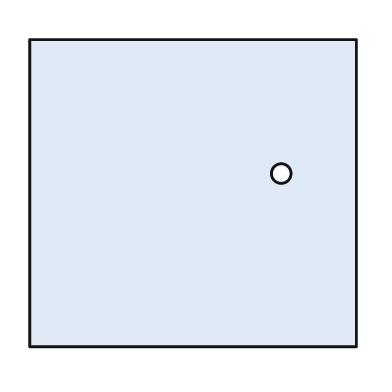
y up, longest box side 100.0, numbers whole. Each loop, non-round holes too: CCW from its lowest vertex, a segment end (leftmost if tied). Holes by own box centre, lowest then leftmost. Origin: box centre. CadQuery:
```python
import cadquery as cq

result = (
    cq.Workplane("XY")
    .moveTo(-50.0, -47.0)
    .lineTo(50.0, -47.0)
    .lineTo(50.0, 47.0)
    .lineTo(-50.0, 47.0)
    .close()
    .moveTo(27.0, 6.0)
    .circle(3.0)
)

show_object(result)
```